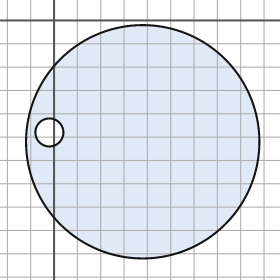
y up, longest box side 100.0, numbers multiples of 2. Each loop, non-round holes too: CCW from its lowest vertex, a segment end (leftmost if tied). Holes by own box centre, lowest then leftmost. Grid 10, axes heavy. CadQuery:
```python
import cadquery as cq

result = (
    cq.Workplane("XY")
    .moveTo(38.0, -52.0)
    .circle(50.0)
    .moveTo(-2.0, -48.0)
    .circle(6.0)
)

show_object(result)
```